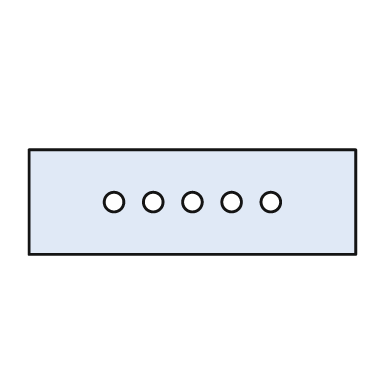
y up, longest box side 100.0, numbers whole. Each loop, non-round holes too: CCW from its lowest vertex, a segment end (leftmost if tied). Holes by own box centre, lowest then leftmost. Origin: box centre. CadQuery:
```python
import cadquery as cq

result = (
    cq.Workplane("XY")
    .moveTo(-50.0, -16.0)
    .lineTo(50.0, -16.0)
    .lineTo(50.0, 16.0)
    .lineTo(-50.0, 16.0)
    .close()
    .moveTo(-24.0, 0.0)
    .circle(3.0)
    .moveTo(-12.0, 0.0)
    .circle(3.0)
    .moveTo(0.0, 0.0)
    .circle(3.0)
    .moveTo(12.0, 0.0)
    .circle(3.0)
    .moveTo(24.0, 0.0)
    .circle(3.0)
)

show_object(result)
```